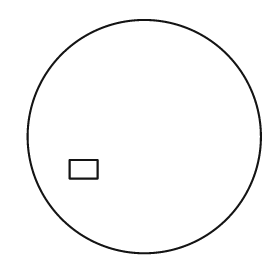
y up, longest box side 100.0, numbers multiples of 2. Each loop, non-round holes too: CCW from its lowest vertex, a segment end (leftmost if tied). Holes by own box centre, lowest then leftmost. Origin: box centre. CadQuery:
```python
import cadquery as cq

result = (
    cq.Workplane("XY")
    .moveTo(0.0, 0.0)
    .circle(50.0)
    .moveTo(-32.0, -18.0)
    .lineTo(-20.0, -18.0)
    .lineTo(-20.0, -10.0)
    .lineTo(-32.0, -10.0)
    .close()
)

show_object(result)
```